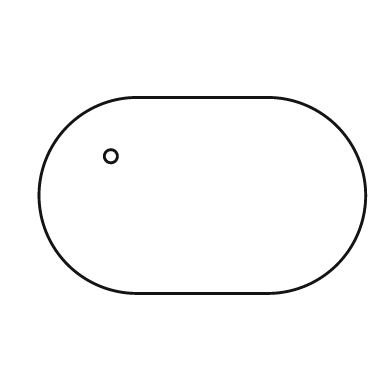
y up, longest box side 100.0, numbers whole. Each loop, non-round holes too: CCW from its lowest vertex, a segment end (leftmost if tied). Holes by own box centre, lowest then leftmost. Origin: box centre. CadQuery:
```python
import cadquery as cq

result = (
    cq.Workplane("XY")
    .moveTo(-20.0, -30.0)
    .lineTo(20.0, -30.0)
    .threePointArc((50.0, 0.0), (20.0, 30.0))
    .lineTo(-20.0, 30.0)
    .threePointArc((-50.0, 0.0), (-20.0, -30.0))
    .close()
    .moveTo(-28.0, 12.0)
    .circle(2.0)
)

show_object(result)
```